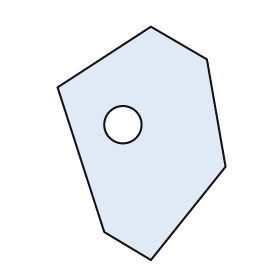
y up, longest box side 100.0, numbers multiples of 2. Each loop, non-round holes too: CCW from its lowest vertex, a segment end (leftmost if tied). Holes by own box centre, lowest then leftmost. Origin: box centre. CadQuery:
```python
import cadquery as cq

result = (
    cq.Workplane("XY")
    .moveTo(4.0, -50.0)
    .lineTo(36.0, -10.0)
    .lineTo(28.0, 36.0)
    .lineTo(4.0, 50.0)
    .lineTo(-36.0, 24.0)
    .lineTo(-16.0, -38.0)
    .close()
    .moveTo(-8.0, 8.0)
    .circle(8.0)
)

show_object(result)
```